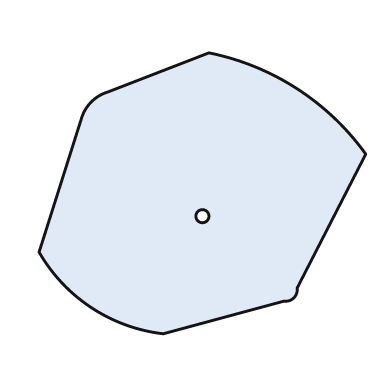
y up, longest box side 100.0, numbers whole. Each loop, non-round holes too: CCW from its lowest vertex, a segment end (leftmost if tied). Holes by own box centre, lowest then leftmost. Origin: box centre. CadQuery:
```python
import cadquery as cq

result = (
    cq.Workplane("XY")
    .moveTo(-12.0, -43.0)
    .lineTo(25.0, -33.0)
    .threePointArc((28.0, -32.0), (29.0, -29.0))
    .lineTo(50.0, 12.0)
    .threePointArc((29.0, 32.0), (2.0, 43.0))
    .lineTo(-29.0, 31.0)
    .threePointArc((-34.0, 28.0), (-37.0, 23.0))
    .lineTo(-50.0, -18.0)
    .threePointArc((-34.0, -35.0), (-12.0, -43.0))
    .close()
    .moveTo(0.0, -7.0)
    .circle(2.0)
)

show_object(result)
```